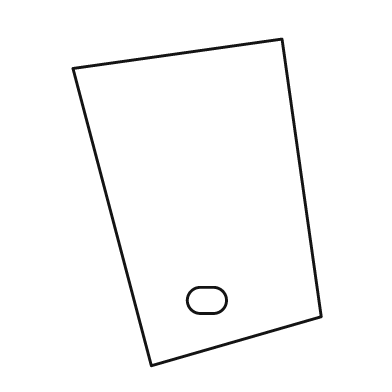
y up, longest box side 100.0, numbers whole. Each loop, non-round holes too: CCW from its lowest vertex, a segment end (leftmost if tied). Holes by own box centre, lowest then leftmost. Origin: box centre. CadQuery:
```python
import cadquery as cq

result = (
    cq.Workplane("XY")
    .moveTo(-14.0, -50.0)
    .lineTo(38.0, -35.0)
    .lineTo(26.0, 50.0)
    .lineTo(-38.0, 41.0)
    .close()
    .moveTo(1.0, -34.0)
    .lineTo(5.0, -34.0)
    .threePointArc((9.0, -30.0), (5.0, -26.0))
    .lineTo(1.0, -26.0)
    .threePointArc((-3.0, -30.0), (1.0, -34.0))
    .close()
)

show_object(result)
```